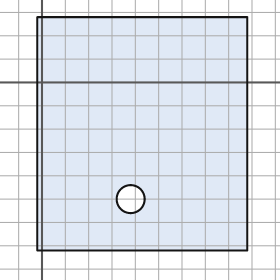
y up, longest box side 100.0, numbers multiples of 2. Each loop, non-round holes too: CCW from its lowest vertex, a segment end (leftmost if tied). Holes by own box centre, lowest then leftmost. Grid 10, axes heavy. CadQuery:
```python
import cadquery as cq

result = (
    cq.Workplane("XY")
    .moveTo(-2.0, -72.0)
    .lineTo(88.0, -72.0)
    .lineTo(88.0, 28.0)
    .lineTo(-2.0, 28.0)
    .close()
    .moveTo(38.0, -50.0)
    .circle(6.0)
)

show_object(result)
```